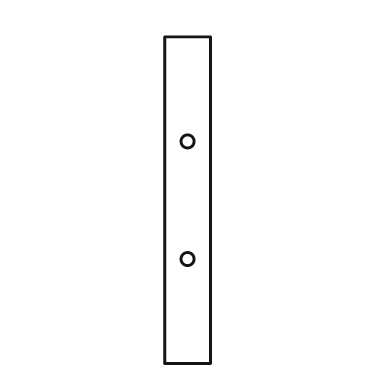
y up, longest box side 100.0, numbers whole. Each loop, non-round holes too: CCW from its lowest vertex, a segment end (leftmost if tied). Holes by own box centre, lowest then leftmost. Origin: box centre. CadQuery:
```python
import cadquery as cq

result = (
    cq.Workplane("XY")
    .moveTo(-7.0, -50.0)
    .lineTo(7.0, -50.0)
    .lineTo(7.0, 50.0)
    .lineTo(-7.0, 50.0)
    .close()
    .moveTo(0.0, -18.0)
    .circle(2.0)
    .moveTo(0.0, 18.0)
    .circle(2.0)
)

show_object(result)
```